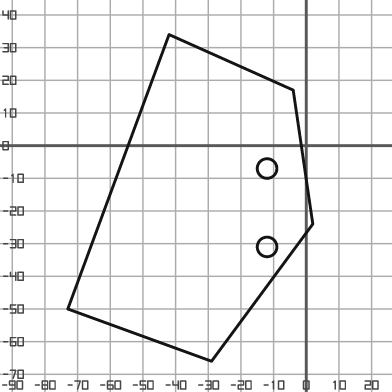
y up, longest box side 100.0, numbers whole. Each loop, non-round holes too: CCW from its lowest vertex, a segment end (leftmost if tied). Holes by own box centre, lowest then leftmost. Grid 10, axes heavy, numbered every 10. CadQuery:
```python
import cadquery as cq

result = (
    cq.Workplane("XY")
    .moveTo(-29.0, -66.0)
    .lineTo(2.0, -24.0)
    .lineTo(-4.0, 17.0)
    .lineTo(-42.0, 34.0)
    .lineTo(-73.0, -50.0)
    .close()
    .moveTo(-12.0, -31.0)
    .circle(3.0)
    .moveTo(-12.0, -7.0)
    .circle(3.0)
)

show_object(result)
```